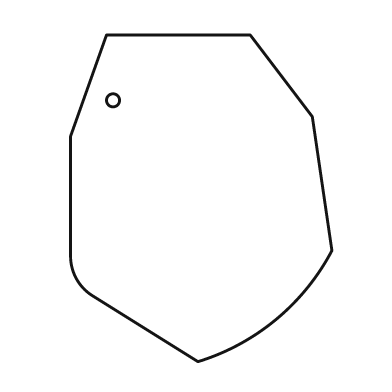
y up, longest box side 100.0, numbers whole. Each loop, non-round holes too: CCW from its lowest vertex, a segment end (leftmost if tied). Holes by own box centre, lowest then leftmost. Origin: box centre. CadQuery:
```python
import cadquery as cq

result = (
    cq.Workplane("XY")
    .moveTo(-1.0, -50.0)
    .threePointArc((23.0, -37.0), (40.0, -16.0))
    .lineTo(34.0, 25.0)
    .lineTo(15.0, 50.0)
    .lineTo(-29.0, 50.0)
    .lineTo(-40.0, 19.0)
    .lineTo(-40.0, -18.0)
    .threePointArc((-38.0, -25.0), (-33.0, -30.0))
    .close()
    .moveTo(-27.0, 30.0)
    .circle(2.0)
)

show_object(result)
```